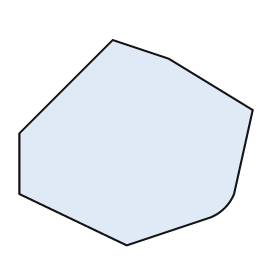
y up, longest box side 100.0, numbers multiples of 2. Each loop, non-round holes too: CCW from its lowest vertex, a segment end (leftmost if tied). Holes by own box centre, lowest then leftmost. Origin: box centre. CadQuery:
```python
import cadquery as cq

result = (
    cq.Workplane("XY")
    .moveTo(-4.0, -44.0)
    .lineTo(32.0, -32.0)
    .threePointArc((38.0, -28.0), (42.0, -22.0))
    .lineTo(50.0, 14.0)
    .lineTo(14.0, 36.0)
    .lineTo(-10.0, 44.0)
    .lineTo(-50.0, 4.0)
    .lineTo(-50.0, -22.0)
    .close()
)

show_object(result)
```